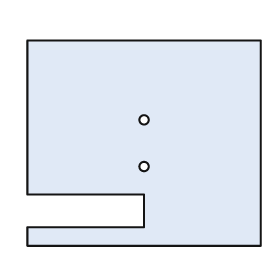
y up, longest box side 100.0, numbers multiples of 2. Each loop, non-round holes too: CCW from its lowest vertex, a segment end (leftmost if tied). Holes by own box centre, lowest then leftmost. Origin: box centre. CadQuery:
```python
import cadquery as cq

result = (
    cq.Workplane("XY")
    .moveTo(-50.0, -44.0)
    .lineTo(50.0, -44.0)
    .lineTo(50.0, 44.0)
    .lineTo(-50.0, 44.0)
    .lineTo(-50.0, -22.0)
    .lineTo(0.0, -22.0)
    .lineTo(0.0, -36.0)
    .lineTo(-50.0, -36.0)
    .close()
    .moveTo(0.0, -10.0)
    .circle(2.0)
    .moveTo(0.0, 10.0)
    .circle(2.0)
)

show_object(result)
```